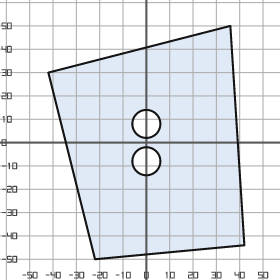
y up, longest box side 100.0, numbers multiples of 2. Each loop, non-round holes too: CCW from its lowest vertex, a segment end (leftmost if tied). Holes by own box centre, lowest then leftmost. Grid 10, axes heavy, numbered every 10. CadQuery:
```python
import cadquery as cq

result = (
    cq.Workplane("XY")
    .moveTo(-22.0, -50.0)
    .lineTo(42.0, -44.0)
    .lineTo(36.0, 50.0)
    .lineTo(-42.0, 30.0)
    .close()
    .moveTo(0.0, -8.0)
    .circle(6.0)
    .moveTo(0.0, 8.0)
    .circle(6.0)
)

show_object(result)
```